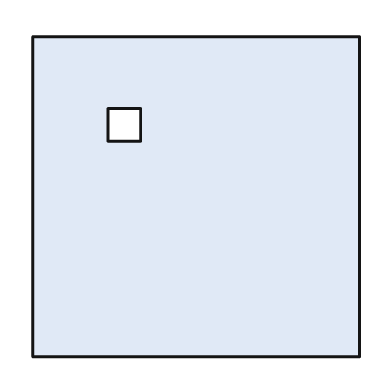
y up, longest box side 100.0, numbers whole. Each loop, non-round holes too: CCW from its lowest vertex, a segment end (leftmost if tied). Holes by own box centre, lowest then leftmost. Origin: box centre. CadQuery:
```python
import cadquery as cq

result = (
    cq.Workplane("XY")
    .moveTo(-50.0, -49.0)
    .lineTo(50.0, -49.0)
    .lineTo(50.0, 49.0)
    .lineTo(-50.0, 49.0)
    .close()
    .moveTo(-27.0, 17.0)
    .lineTo(-17.0, 17.0)
    .lineTo(-17.0, 27.0)
    .lineTo(-27.0, 27.0)
    .close()
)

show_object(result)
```